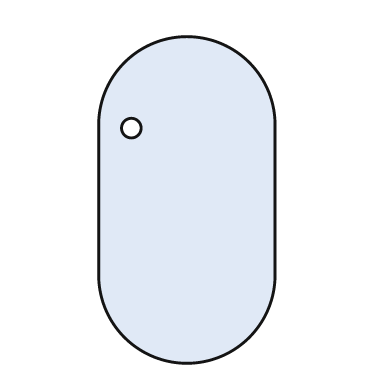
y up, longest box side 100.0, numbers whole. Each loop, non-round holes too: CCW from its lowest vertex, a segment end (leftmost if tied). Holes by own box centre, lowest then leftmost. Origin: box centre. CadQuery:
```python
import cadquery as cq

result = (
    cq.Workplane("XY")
    .moveTo(-27.0, -23.0)
    .threePointArc((0.0, -50.0), (27.0, -23.0))
    .lineTo(27.0, 23.0)
    .threePointArc((0.0, 50.0), (-27.0, 23.0))
    .close()
    .moveTo(-17.0, 22.0)
    .circle(3.0)
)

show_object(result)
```